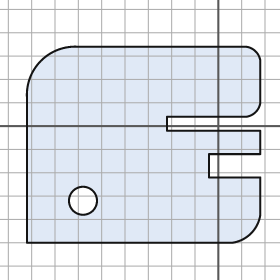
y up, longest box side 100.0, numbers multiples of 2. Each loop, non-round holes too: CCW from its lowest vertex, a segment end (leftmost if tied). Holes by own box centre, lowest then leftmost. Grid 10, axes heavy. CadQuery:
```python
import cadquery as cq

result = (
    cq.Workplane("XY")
    .moveTo(-82.0, -50.0)
    .lineTo(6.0, -50.0)
    .threePointArc((14.0, -46.0), (18.0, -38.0))
    .lineTo(18.0, -22.0)
    .lineTo(-4.0, -22.0)
    .lineTo(-4.0, -12.0)
    .lineTo(18.0, -12.0)
    .lineTo(18.0, -2.0)
    .lineTo(-22.0, -2.0)
    .lineTo(-22.0, 4.0)
    .lineTo(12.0, 4.0)
    .threePointArc((16.0, 6.0), (18.0, 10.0))
    .lineTo(18.0, 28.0)
    .threePointArc((16.0, 32.0), (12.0, 34.0))
    .lineTo(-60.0, 34.0)
    .threePointArc((-76.0, 28.0), (-82.0, 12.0))
    .close()
    .moveTo(-58.0, -32.0)
    .circle(6.0)
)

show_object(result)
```